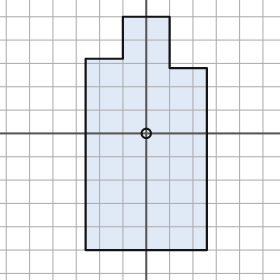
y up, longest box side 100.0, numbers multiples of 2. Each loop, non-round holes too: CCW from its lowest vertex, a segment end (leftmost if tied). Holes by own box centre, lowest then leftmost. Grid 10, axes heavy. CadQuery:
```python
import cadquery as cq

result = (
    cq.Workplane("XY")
    .moveTo(-26.0, -50.0)
    .lineTo(26.0, -50.0)
    .lineTo(26.0, 28.0)
    .lineTo(10.0, 28.0)
    .lineTo(10.0, 50.0)
    .lineTo(-10.0, 50.0)
    .lineTo(-10.0, 32.0)
    .lineTo(-26.0, 32.0)
    .close()
    .moveTo(0.0, 0.0)
    .circle(2.0)
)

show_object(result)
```